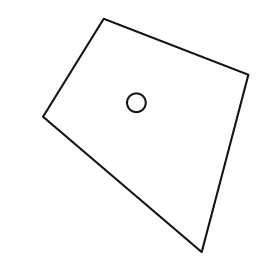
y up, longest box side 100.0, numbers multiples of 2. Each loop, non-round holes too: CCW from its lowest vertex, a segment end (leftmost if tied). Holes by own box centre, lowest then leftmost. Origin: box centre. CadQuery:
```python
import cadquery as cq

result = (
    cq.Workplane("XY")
    .moveTo(24.0, -50.0)
    .lineTo(44.0, 26.0)
    .lineTo(-18.0, 50.0)
    .lineTo(-44.0, 8.0)
    .close()
    .moveTo(-4.0, 14.0)
    .circle(4.0)
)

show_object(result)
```